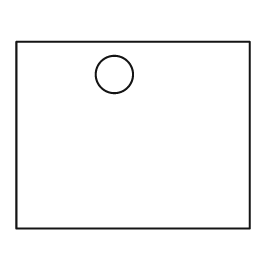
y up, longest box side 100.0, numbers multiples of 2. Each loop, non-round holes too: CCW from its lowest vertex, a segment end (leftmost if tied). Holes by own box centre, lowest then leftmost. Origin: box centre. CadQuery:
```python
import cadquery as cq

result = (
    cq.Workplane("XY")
    .moveTo(-50.0, -40.0)
    .lineTo(50.0, -40.0)
    .lineTo(50.0, 40.0)
    .lineTo(-50.0, 40.0)
    .close()
    .moveTo(-8.0, 26.0)
    .circle(8.0)
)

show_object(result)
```